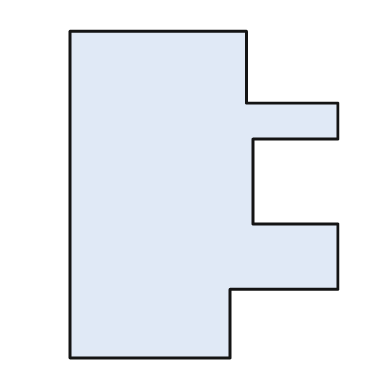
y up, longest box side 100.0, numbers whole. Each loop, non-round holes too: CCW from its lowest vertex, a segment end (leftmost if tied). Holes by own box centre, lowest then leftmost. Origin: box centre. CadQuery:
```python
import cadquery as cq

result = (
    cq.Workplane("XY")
    .moveTo(-41.0, -50.0)
    .lineTo(8.0, -50.0)
    .lineTo(8.0, -29.0)
    .lineTo(41.0, -29.0)
    .lineTo(41.0, -9.0)
    .lineTo(15.0, -9.0)
    .lineTo(15.0, 17.0)
    .lineTo(41.0, 17.0)
    .lineTo(41.0, 28.0)
    .lineTo(13.0, 28.0)
    .lineTo(13.0, 50.0)
    .lineTo(-41.0, 50.0)
    .close()
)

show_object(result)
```